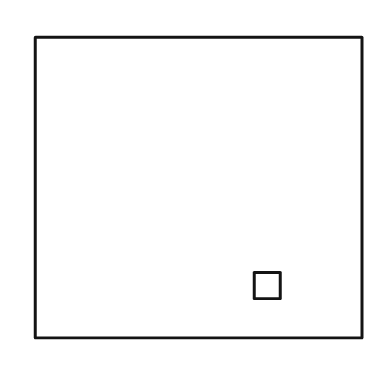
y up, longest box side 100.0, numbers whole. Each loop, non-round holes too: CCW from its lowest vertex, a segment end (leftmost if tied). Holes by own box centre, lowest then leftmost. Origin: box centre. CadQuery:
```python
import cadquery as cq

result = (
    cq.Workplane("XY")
    .moveTo(-50.0, -46.0)
    .lineTo(50.0, -46.0)
    .lineTo(50.0, 46.0)
    .lineTo(-50.0, 46.0)
    .close()
    .moveTo(17.0, -34.0)
    .lineTo(25.0, -34.0)
    .lineTo(25.0, -26.0)
    .lineTo(17.0, -26.0)
    .close()
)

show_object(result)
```